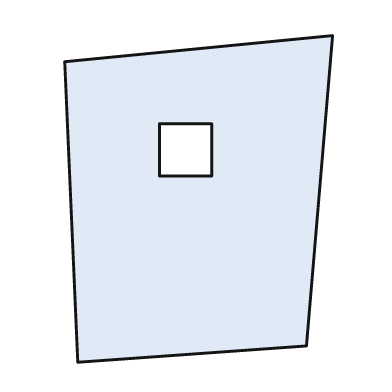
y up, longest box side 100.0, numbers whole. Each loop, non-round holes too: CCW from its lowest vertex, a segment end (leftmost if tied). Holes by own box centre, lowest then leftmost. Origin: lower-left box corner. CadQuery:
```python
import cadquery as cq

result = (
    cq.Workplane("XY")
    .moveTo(4.0, 0.0)
    .lineTo(74.0, 5.0)
    .lineTo(82.0, 100.0)
    .lineTo(0.0, 92.0)
    .close()
    .moveTo(29.0, 57.0)
    .lineTo(45.0, 57.0)
    .lineTo(45.0, 73.0)
    .lineTo(29.0, 73.0)
    .close()
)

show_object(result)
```